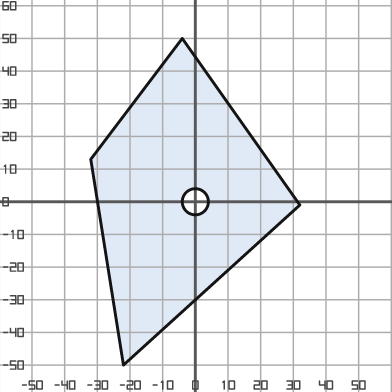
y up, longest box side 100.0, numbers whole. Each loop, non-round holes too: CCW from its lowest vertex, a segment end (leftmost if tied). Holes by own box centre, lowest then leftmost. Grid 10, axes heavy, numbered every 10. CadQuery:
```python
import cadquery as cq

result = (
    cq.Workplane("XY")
    .moveTo(-22.0, -50.0)
    .lineTo(32.0, -1.0)
    .lineTo(-4.0, 50.0)
    .lineTo(-32.0, 13.0)
    .close()
    .moveTo(0.0, 0.0)
    .circle(4.0)
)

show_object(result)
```